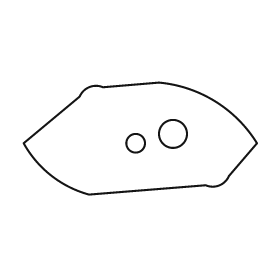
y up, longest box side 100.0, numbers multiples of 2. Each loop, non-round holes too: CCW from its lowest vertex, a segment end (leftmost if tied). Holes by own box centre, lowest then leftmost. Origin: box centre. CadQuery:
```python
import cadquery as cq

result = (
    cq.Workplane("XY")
    .moveTo(-22.0, -24.0)
    .lineTo(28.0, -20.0)
    .threePointArc((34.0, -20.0), (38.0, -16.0))
    .lineTo(50.0, -2.0)
    .threePointArc((32.0, 16.0), (8.0, 24.0))
    .lineTo(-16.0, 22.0)
    .threePointArc((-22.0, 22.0), (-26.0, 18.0))
    .lineTo(-50.0, -2.0)
    .threePointArc((-38.0, -16.0), (-22.0, -24.0))
    .close()
    .moveTo(-2.0, -2.0)
    .circle(4.0)
    .moveTo(14.0, 2.0)
    .circle(6.0)
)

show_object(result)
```